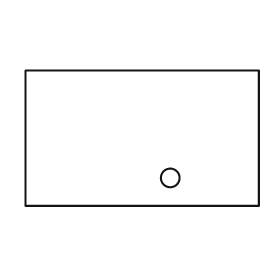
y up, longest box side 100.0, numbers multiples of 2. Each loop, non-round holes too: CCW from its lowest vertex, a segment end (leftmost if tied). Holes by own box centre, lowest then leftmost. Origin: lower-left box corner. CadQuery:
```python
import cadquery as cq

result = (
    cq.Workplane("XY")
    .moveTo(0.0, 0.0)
    .lineTo(100.0, 0.0)
    .lineTo(100.0, 58.0)
    .lineTo(0.0, 58.0)
    .close()
    .moveTo(62.0, 12.0)
    .circle(4.0)
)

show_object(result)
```